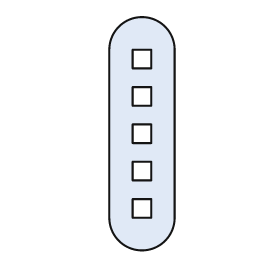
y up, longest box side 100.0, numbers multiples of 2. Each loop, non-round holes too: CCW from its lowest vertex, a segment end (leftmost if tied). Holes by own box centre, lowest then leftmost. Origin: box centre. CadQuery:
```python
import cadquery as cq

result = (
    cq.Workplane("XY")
    .moveTo(-14.0, -36.0)
    .threePointArc((0.0, -50.0), (14.0, -36.0))
    .lineTo(14.0, 36.0)
    .threePointArc((0.0, 50.0), (-14.0, 36.0))
    .close()
    .moveTo(-4.0, -36.0)
    .lineTo(4.0, -36.0)
    .lineTo(4.0, -28.0)
    .lineTo(-4.0, -28.0)
    .close()
    .moveTo(-4.0, -20.0)
    .lineTo(4.0, -20.0)
    .lineTo(4.0, -12.0)
    .lineTo(-4.0, -12.0)
    .close()
    .moveTo(-4.0, -4.0)
    .lineTo(4.0, -4.0)
    .lineTo(4.0, 4.0)
    .lineTo(-4.0, 4.0)
    .close()
    .moveTo(-4.0, 12.0)
    .lineTo(4.0, 12.0)
    .lineTo(4.0, 20.0)
    .lineTo(-4.0, 20.0)
    .close()
    .moveTo(-4.0, 28.0)
    .lineTo(4.0, 28.0)
    .lineTo(4.0, 36.0)
    .lineTo(-4.0, 36.0)
    .close()
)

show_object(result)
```